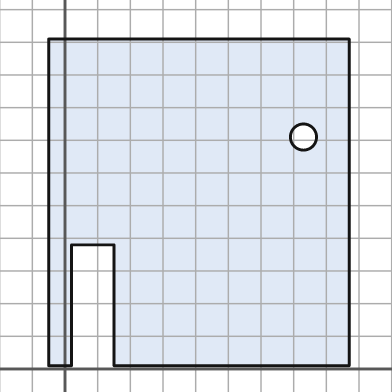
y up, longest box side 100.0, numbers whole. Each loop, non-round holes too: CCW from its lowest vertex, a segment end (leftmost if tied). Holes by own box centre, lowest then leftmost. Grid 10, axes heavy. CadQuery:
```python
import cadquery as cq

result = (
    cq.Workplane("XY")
    .moveTo(-5.0, 1.0)
    .lineTo(2.0, 1.0)
    .lineTo(2.0, 38.0)
    .lineTo(15.0, 38.0)
    .lineTo(15.0, 1.0)
    .lineTo(87.0, 1.0)
    .lineTo(87.0, 101.0)
    .lineTo(-5.0, 101.0)
    .close()
    .moveTo(73.0, 71.0)
    .circle(4.0)
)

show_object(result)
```